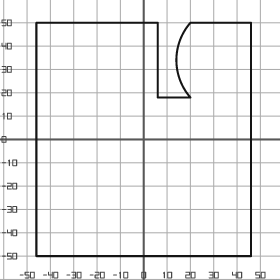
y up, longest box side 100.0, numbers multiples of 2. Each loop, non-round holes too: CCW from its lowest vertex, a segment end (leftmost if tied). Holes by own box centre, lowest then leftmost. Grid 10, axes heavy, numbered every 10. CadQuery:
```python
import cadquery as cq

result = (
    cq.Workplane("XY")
    .moveTo(-46.0, -50.0)
    .lineTo(46.0, -50.0)
    .lineTo(46.0, 50.0)
    .lineTo(20.0, 50.0)
    .threePointArc((14.0, 34.0), (20.0, 18.0))
    .lineTo(6.0, 18.0)
    .lineTo(6.0, 50.0)
    .lineTo(-46.0, 50.0)
    .close()
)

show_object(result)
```